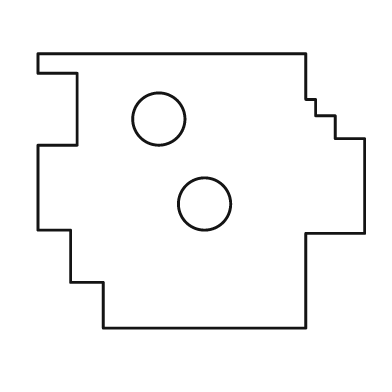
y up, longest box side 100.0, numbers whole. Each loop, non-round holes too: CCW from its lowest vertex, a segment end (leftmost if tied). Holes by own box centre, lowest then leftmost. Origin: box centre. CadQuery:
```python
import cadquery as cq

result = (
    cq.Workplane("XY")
    .moveTo(-30.0, -42.0)
    .lineTo(32.0, -42.0)
    .lineTo(32.0, -13.0)
    .lineTo(50.0, -13.0)
    .lineTo(50.0, 16.0)
    .lineTo(41.0, 16.0)
    .lineTo(41.0, 23.0)
    .lineTo(35.0, 23.0)
    .lineTo(35.0, 28.0)
    .lineTo(32.0, 28.0)
    .lineTo(32.0, 42.0)
    .lineTo(-50.0, 42.0)
    .lineTo(-50.0, 36.0)
    .lineTo(-38.0, 36.0)
    .lineTo(-38.0, 14.0)
    .lineTo(-50.0, 14.0)
    .lineTo(-50.0, -12.0)
    .lineTo(-40.0, -12.0)
    .lineTo(-40.0, -28.0)
    .lineTo(-30.0, -28.0)
    .close()
    .moveTo(1.0, -4.0)
    .circle(8.0)
    .moveTo(-13.0, 22.0)
    .circle(8.0)
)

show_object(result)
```